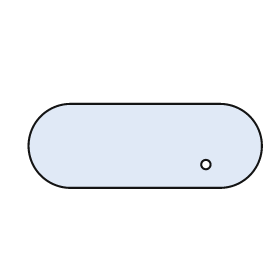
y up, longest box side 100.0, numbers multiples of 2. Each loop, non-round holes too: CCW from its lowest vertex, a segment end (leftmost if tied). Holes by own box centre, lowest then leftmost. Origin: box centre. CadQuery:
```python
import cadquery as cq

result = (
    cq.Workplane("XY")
    .moveTo(-32.0, -18.0)
    .lineTo(32.0, -18.0)
    .threePointArc((50.0, 0.0), (32.0, 18.0))
    .lineTo(-32.0, 18.0)
    .threePointArc((-50.0, 0.0), (-32.0, -18.0))
    .close()
    .moveTo(26.0, -8.0)
    .circle(2.0)
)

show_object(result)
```